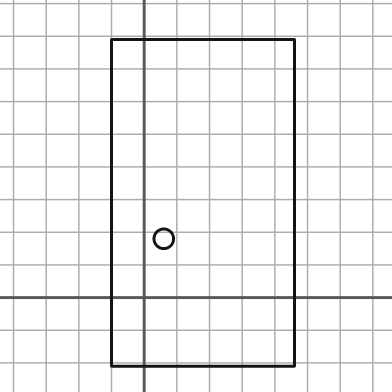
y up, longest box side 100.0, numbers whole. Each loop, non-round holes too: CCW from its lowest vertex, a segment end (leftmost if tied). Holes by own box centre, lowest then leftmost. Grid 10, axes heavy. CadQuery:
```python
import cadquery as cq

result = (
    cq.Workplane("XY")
    .moveTo(-10.0, -21.0)
    .lineTo(46.0, -21.0)
    .lineTo(46.0, 79.0)
    .lineTo(-10.0, 79.0)
    .close()
    .moveTo(6.0, 18.0)
    .circle(3.0)
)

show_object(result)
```